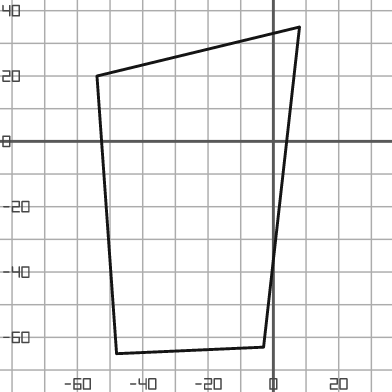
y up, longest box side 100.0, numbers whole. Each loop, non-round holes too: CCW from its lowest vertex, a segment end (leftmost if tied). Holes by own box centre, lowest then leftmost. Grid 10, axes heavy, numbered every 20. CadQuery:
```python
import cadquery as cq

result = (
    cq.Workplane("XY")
    .moveTo(-48.0, -65.0)
    .lineTo(-3.0, -63.0)
    .lineTo(8.0, 35.0)
    .lineTo(-54.0, 20.0)
    .close()
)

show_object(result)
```